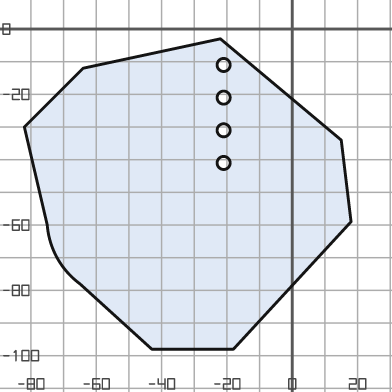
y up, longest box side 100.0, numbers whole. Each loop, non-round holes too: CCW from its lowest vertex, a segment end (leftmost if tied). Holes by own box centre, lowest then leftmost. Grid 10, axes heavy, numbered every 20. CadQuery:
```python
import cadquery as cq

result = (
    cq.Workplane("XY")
    .moveTo(-43.0, -98.0)
    .lineTo(-18.0, -98.0)
    .lineTo(18.0, -59.0)
    .lineTo(15.0, -34.0)
    .lineTo(-22.0, -3.0)
    .lineTo(-64.0, -12.0)
    .lineTo(-82.0, -30.0)
    .lineTo(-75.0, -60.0)
    .threePointArc((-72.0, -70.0), (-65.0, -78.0))
    .close()
    .moveTo(-21.0, -41.0)
    .circle(2.0)
    .moveTo(-21.0, -31.0)
    .circle(2.0)
    .moveTo(-21.0, -21.0)
    .circle(2.0)
    .moveTo(-21.0, -11.0)
    .circle(2.0)
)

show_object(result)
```